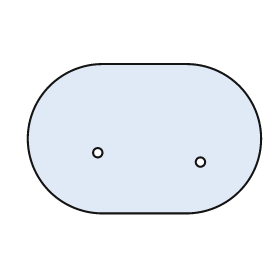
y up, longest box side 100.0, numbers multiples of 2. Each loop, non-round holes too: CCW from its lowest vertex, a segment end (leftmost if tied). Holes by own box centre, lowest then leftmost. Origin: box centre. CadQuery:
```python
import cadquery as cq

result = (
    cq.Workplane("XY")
    .moveTo(-18.0, -32.0)
    .lineTo(18.0, -32.0)
    .threePointArc((50.0, 0.0), (18.0, 32.0))
    .lineTo(-18.0, 32.0)
    .threePointArc((-50.0, 0.0), (-18.0, -32.0))
    .close()
    .moveTo(24.0, -10.0)
    .circle(2.0)
    .moveTo(-20.0, -6.0)
    .circle(2.0)
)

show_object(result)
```